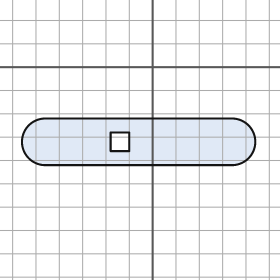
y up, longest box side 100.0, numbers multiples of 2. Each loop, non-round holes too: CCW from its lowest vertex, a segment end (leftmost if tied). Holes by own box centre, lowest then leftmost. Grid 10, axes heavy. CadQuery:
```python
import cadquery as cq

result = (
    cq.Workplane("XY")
    .moveTo(-46.0, -42.0)
    .lineTo(34.0, -42.0)
    .threePointArc((44.0, -32.0), (34.0, -22.0))
    .lineTo(-46.0, -22.0)
    .threePointArc((-56.0, -32.0), (-46.0, -42.0))
    .close()
    .moveTo(-18.0, -36.0)
    .lineTo(-10.0, -36.0)
    .lineTo(-10.0, -28.0)
    .lineTo(-18.0, -28.0)
    .close()
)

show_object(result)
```